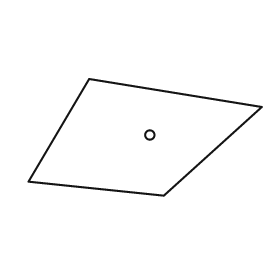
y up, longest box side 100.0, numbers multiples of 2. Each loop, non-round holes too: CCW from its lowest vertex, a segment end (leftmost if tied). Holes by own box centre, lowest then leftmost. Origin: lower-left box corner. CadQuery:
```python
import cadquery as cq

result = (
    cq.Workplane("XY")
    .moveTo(58.0, 0.0)
    .lineTo(100.0, 38.0)
    .lineTo(26.0, 50.0)
    .lineTo(0.0, 6.0)
    .close()
    .moveTo(52.0, 26.0)
    .circle(2.0)
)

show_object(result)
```